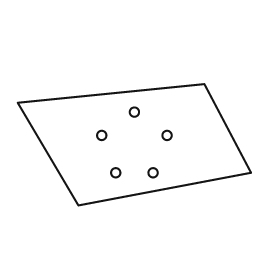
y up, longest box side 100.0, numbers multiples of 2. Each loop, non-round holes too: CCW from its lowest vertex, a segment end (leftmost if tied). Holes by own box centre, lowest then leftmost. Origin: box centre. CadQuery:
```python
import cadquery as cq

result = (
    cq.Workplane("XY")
    .moveTo(-24.0, -26.0)
    .lineTo(50.0, -12.0)
    .lineTo(30.0, 26.0)
    .lineTo(-50.0, 18.0)
    .close()
    .moveTo(-8.0, -12.0)
    .circle(2.0)
    .moveTo(8.0, -12.0)
    .circle(2.0)
    .moveTo(-14.0, 4.0)
    .circle(2.0)
    .moveTo(14.0, 4.0)
    .circle(2.0)
    .moveTo(0.0, 14.0)
    .circle(2.0)
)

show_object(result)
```